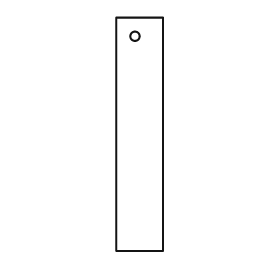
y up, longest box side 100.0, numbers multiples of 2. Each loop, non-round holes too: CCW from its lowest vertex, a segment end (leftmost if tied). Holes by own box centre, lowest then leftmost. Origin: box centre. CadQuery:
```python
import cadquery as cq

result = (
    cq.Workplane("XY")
    .moveTo(-10.0, -50.0)
    .lineTo(10.0, -50.0)
    .lineTo(10.0, 50.0)
    .lineTo(-10.0, 50.0)
    .close()
    .moveTo(-2.0, 42.0)
    .circle(2.0)
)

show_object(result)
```